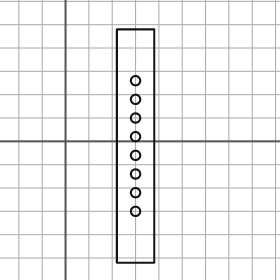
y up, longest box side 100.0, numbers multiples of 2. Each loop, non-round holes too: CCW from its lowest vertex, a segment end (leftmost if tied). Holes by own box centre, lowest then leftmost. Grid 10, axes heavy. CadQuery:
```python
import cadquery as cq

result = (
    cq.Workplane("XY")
    .moveTo(22.0, -52.0)
    .lineTo(38.0, -52.0)
    .lineTo(38.0, 48.0)
    .lineTo(22.0, 48.0)
    .close()
    .moveTo(30.0, -30.0)
    .circle(2.0)
    .moveTo(30.0, -22.0)
    .circle(2.0)
    .moveTo(30.0, -14.0)
    .circle(2.0)
    .moveTo(30.0, -6.0)
    .circle(2.0)
    .moveTo(30.0, 2.0)
    .circle(2.0)
    .moveTo(30.0, 10.0)
    .circle(2.0)
    .moveTo(30.0, 18.0)
    .circle(2.0)
    .moveTo(30.0, 26.0)
    .circle(2.0)
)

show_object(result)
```